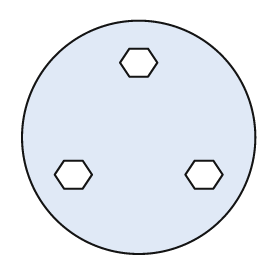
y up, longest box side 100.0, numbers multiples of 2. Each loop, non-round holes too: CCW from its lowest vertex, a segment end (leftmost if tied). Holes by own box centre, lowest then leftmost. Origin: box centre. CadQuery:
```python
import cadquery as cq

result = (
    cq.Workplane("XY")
    .moveTo(0.0, 0.0)
    .circle(50.0)
    .moveTo(-32.0, -22.0)
    .lineTo(-24.0, -22.0)
    .lineTo(-20.0, -16.0)
    .lineTo(-24.0, -10.0)
    .lineTo(-32.0, -10.0)
    .lineTo(-36.0, -16.0)
    .close()
    .moveTo(24.0, -22.0)
    .lineTo(32.0, -22.0)
    .lineTo(36.0, -16.0)
    .lineTo(32.0, -10.0)
    .lineTo(24.0, -10.0)
    .lineTo(20.0, -16.0)
    .close()
    .moveTo(-4.0, 26.0)
    .lineTo(4.0, 26.0)
    .lineTo(8.0, 32.0)
    .lineTo(4.0, 38.0)
    .lineTo(-4.0, 38.0)
    .lineTo(-8.0, 32.0)
    .close()
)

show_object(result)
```